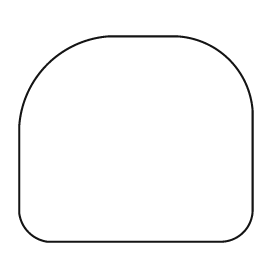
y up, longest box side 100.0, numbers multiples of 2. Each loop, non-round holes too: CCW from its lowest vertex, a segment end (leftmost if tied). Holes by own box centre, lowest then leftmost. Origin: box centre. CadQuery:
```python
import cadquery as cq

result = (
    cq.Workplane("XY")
    .moveTo(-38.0, -44.0)
    .lineTo(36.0, -44.0)
    .threePointArc((46.0, -40.0), (50.0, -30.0))
    .lineTo(50.0, 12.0)
    .threePointArc((40.0, 34.0), (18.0, 44.0))
    .lineTo(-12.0, 44.0)
    .threePointArc((-38.0, 32.0), (-50.0, 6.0))
    .lineTo(-50.0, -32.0)
    .threePointArc((-46.0, -40.0), (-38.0, -44.0))
    .close()
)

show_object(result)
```